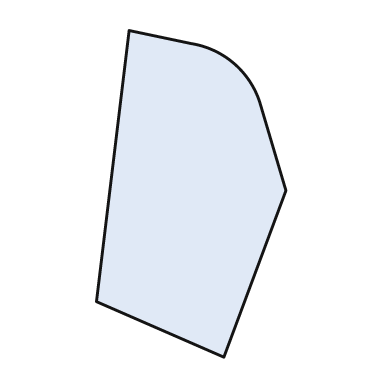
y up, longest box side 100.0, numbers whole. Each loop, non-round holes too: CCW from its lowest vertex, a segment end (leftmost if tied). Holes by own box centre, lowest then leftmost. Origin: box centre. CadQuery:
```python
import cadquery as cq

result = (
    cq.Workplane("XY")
    .moveTo(10.0, -50.0)
    .lineTo(29.0, 1.0)
    .lineTo(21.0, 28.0)
    .threePointArc((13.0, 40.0), (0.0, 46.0))
    .lineTo(-19.0, 50.0)
    .lineTo(-29.0, -33.0)
    .close()
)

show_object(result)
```